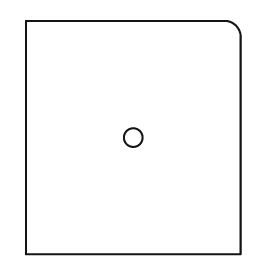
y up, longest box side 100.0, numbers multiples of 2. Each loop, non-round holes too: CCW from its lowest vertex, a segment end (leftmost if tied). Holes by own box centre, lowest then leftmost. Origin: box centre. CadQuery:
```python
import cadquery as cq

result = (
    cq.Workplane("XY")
    .moveTo(-46.0, -50.0)
    .lineTo(46.0, -50.0)
    .lineTo(46.0, 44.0)
    .threePointArc((44.0, 48.0), (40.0, 50.0))
    .lineTo(-46.0, 50.0)
    .close()
    .moveTo(0.0, 0.0)
    .circle(4.0)
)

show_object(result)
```